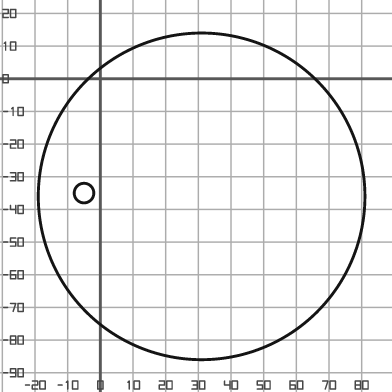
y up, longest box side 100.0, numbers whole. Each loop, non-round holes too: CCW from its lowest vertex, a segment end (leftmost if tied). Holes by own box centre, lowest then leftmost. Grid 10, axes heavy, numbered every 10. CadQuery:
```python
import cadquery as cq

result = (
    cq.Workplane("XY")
    .moveTo(31.0, -36.0)
    .circle(50.0)
    .moveTo(-5.0, -35.0)
    .circle(3.0)
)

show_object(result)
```